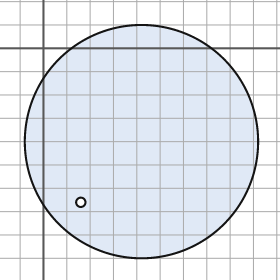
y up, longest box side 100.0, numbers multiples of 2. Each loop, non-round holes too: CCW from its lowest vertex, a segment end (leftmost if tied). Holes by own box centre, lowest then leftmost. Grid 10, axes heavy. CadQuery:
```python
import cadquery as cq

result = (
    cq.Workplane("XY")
    .moveTo(42.0, -40.0)
    .circle(50.0)
    .moveTo(16.0, -66.0)
    .circle(2.0)
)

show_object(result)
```